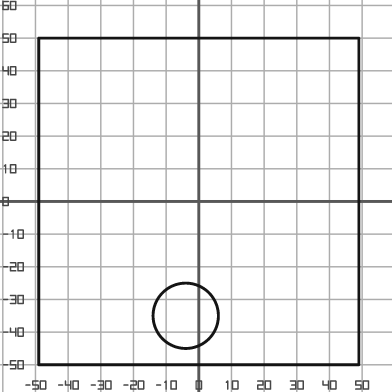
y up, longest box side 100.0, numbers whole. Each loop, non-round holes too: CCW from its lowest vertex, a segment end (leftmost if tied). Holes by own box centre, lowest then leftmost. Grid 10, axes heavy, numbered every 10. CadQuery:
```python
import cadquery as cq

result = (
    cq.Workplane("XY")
    .moveTo(-49.0, -50.0)
    .lineTo(49.0, -50.0)
    .lineTo(49.0, 50.0)
    .lineTo(-49.0, 50.0)
    .close()
    .moveTo(-4.0, -35.0)
    .circle(10.0)
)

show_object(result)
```